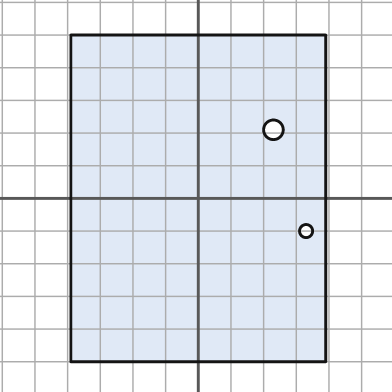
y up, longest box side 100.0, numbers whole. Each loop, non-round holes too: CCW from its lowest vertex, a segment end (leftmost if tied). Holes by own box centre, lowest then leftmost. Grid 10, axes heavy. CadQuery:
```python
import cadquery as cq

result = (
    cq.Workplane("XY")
    .moveTo(-39.0, -50.0)
    .lineTo(39.0, -50.0)
    .lineTo(39.0, 50.0)
    .lineTo(-39.0, 50.0)
    .close()
    .moveTo(33.0, -10.0)
    .circle(2.0)
    .moveTo(23.0, 21.0)
    .circle(3.0)
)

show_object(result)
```